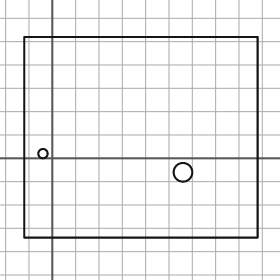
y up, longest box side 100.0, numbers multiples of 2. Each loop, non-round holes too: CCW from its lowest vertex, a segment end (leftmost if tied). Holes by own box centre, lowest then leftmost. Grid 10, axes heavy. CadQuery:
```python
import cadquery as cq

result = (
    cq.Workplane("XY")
    .moveTo(-12.0, -34.0)
    .lineTo(88.0, -34.0)
    .lineTo(88.0, 52.0)
    .lineTo(-12.0, 52.0)
    .close()
    .moveTo(56.0, -6.0)
    .circle(4.0)
    .moveTo(-4.0, 2.0)
    .circle(2.0)
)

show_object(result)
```